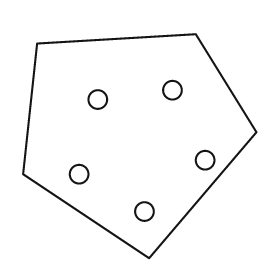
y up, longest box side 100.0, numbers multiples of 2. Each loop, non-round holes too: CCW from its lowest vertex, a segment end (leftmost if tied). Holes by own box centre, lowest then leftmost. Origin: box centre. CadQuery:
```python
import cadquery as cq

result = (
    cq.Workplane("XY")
    .moveTo(4.0, -48.0)
    .lineTo(50.0, 6.0)
    .lineTo(24.0, 48.0)
    .lineTo(-44.0, 44.0)
    .lineTo(-50.0, -12.0)
    .close()
    .moveTo(2.0, -28.0)
    .circle(4.0)
    .moveTo(-26.0, -12.0)
    .circle(4.0)
    .moveTo(28.0, -6.0)
    .circle(4.0)
    .moveTo(-18.0, 20.0)
    .circle(4.0)
    .moveTo(14.0, 24.0)
    .circle(4.0)
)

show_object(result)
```